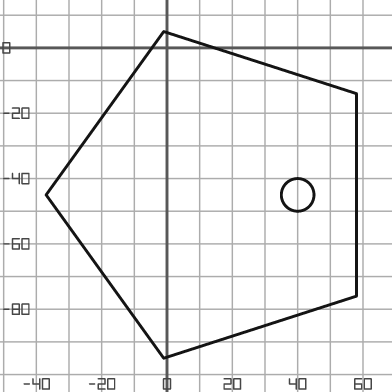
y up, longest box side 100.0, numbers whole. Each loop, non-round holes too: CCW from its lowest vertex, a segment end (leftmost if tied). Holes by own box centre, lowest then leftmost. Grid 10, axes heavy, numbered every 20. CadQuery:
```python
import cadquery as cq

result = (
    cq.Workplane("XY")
    .moveTo(-1.0, -95.0)
    .lineTo(58.0, -76.0)
    .lineTo(58.0, -14.0)
    .lineTo(-1.0, 5.0)
    .lineTo(-37.0, -45.0)
    .close()
    .moveTo(40.0, -45.0)
    .circle(5.0)
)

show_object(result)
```